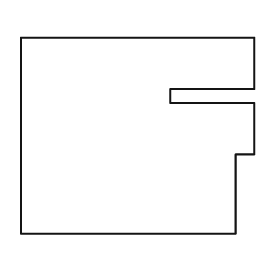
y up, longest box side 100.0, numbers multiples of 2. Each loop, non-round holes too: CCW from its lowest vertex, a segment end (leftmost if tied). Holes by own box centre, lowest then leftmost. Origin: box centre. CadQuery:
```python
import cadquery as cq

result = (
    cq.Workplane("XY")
    .moveTo(-50.0, -42.0)
    .lineTo(42.0, -42.0)
    .lineTo(42.0, -8.0)
    .lineTo(50.0, -8.0)
    .lineTo(50.0, 14.0)
    .lineTo(14.0, 14.0)
    .lineTo(14.0, 20.0)
    .lineTo(50.0, 20.0)
    .lineTo(50.0, 42.0)
    .lineTo(-50.0, 42.0)
    .close()
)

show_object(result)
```